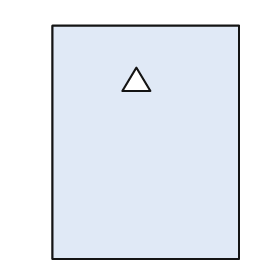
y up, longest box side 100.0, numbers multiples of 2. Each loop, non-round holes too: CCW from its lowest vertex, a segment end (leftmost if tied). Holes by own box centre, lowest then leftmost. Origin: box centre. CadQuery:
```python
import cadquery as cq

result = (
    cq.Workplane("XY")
    .moveTo(-40.0, -50.0)
    .lineTo(40.0, -50.0)
    .lineTo(40.0, 50.0)
    .lineTo(-40.0, 50.0)
    .close()
    .moveTo(-10.0, 22.0)
    .lineTo(2.0, 22.0)
    .lineTo(-4.0, 32.0)
    .close()
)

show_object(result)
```